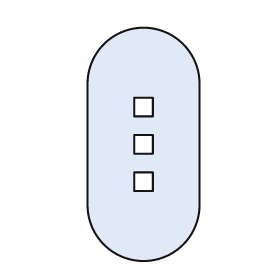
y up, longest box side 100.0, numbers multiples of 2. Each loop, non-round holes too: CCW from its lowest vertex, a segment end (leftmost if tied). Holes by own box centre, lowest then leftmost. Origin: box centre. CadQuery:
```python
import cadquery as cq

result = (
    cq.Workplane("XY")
    .moveTo(-24.0, -26.0)
    .threePointArc((0.0, -50.0), (24.0, -26.0))
    .lineTo(24.0, 26.0)
    .threePointArc((0.0, 50.0), (-24.0, 26.0))
    .close()
    .moveTo(-4.0, -20.0)
    .lineTo(4.0, -20.0)
    .lineTo(4.0, -12.0)
    .lineTo(-4.0, -12.0)
    .close()
    .moveTo(-4.0, -4.0)
    .lineTo(4.0, -4.0)
    .lineTo(4.0, 4.0)
    .lineTo(-4.0, 4.0)
    .close()
    .moveTo(-4.0, 12.0)
    .lineTo(4.0, 12.0)
    .lineTo(4.0, 20.0)
    .lineTo(-4.0, 20.0)
    .close()
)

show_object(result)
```